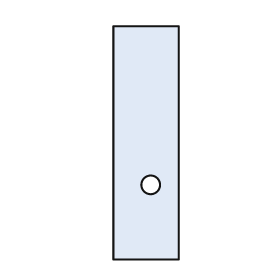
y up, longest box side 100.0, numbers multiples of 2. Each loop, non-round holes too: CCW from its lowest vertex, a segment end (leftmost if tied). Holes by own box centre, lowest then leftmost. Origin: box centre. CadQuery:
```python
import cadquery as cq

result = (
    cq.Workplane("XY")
    .moveTo(-14.0, -50.0)
    .lineTo(14.0, -50.0)
    .lineTo(14.0, 50.0)
    .lineTo(-14.0, 50.0)
    .close()
    .moveTo(2.0, -18.0)
    .circle(4.0)
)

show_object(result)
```